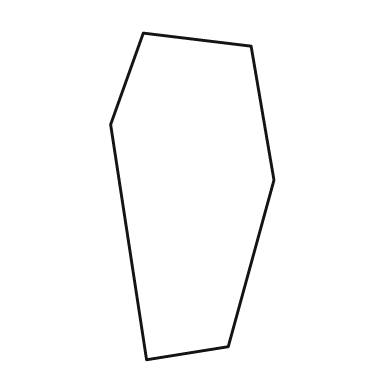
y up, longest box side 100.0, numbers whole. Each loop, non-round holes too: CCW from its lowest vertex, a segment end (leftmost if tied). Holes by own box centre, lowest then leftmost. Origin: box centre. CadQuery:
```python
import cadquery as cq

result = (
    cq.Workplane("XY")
    .moveTo(-14.0, -50.0)
    .lineTo(11.0, -46.0)
    .lineTo(25.0, 5.0)
    .lineTo(18.0, 46.0)
    .lineTo(-15.0, 50.0)
    .lineTo(-25.0, 22.0)
    .close()
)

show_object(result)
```